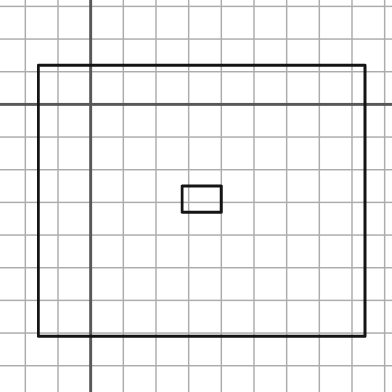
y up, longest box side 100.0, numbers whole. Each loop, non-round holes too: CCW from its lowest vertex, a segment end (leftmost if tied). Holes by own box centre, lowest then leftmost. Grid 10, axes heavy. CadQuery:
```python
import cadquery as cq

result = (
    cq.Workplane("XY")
    .moveTo(-16.0, -71.0)
    .lineTo(84.0, -71.0)
    .lineTo(84.0, 12.0)
    .lineTo(-16.0, 12.0)
    .close()
    .moveTo(28.0, -33.0)
    .lineTo(40.0, -33.0)
    .lineTo(40.0, -25.0)
    .lineTo(28.0, -25.0)
    .close()
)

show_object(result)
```